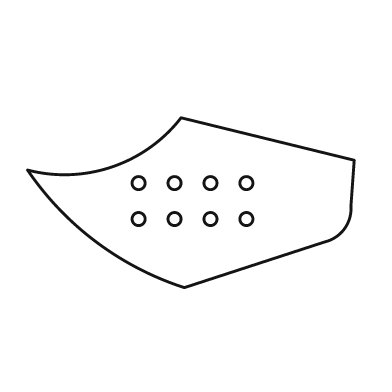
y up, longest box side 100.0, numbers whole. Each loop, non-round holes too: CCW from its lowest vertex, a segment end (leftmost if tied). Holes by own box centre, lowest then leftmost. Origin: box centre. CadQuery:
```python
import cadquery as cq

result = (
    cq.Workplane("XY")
    .moveTo(-2.0, -26.0)
    .lineTo(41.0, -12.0)
    .threePointArc((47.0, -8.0), (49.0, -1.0))
    .lineTo(50.0, 13.0)
    .lineTo(-3.0, 26.0)
    .threePointArc((-24.0, 11.0), (-50.0, 10.0))
    .threePointArc((-29.0, -12.0), (-2.0, -26.0))
    .close()
    .moveTo(-16.0, -5.0)
    .circle(2.0)
    .moveTo(-5.0, -5.0)
    .circle(2.0)
    .moveTo(6.0, -5.0)
    .circle(2.0)
    .moveTo(17.0, -5.0)
    .circle(2.0)
    .moveTo(-16.0, 6.0)
    .circle(2.0)
    .moveTo(-5.0, 6.0)
    .circle(2.0)
    .moveTo(6.0, 6.0)
    .circle(2.0)
    .moveTo(17.0, 6.0)
    .circle(2.0)
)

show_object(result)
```